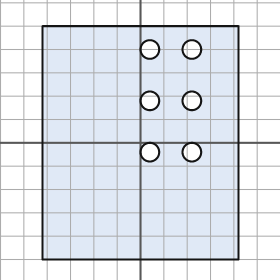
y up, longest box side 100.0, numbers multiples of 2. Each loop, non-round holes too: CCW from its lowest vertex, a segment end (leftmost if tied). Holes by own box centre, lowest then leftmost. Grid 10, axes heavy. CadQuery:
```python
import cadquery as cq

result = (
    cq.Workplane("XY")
    .moveTo(-42.0, -50.0)
    .lineTo(42.0, -50.0)
    .lineTo(42.0, 50.0)
    .lineTo(-42.0, 50.0)
    .close()
    .moveTo(4.0, -4.0)
    .circle(4.0)
    .moveTo(22.0, -4.0)
    .circle(4.0)
    .moveTo(4.0, 18.0)
    .circle(4.0)
    .moveTo(22.0, 18.0)
    .circle(4.0)
    .moveTo(4.0, 40.0)
    .circle(4.0)
    .moveTo(22.0, 40.0)
    .circle(4.0)
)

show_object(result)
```